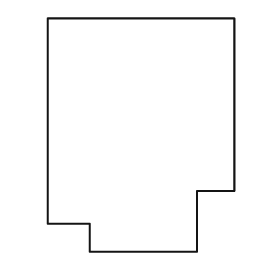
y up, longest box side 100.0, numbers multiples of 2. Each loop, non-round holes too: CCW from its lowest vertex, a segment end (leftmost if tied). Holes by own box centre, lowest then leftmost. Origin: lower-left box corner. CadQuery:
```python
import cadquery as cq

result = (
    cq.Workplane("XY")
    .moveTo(18.0, 0.0)
    .lineTo(64.0, 0.0)
    .lineTo(64.0, 26.0)
    .lineTo(80.0, 26.0)
    .lineTo(80.0, 100.0)
    .lineTo(0.0, 100.0)
    .lineTo(0.0, 12.0)
    .lineTo(18.0, 12.0)
    .close()
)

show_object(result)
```